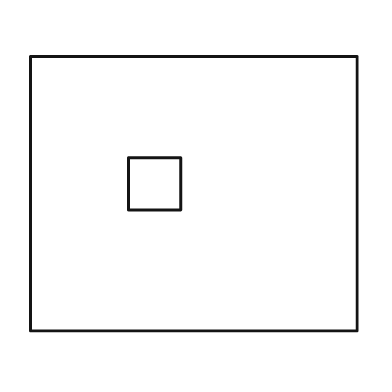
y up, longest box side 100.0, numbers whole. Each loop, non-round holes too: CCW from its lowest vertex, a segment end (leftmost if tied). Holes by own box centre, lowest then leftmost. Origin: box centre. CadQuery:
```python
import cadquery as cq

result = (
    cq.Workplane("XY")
    .moveTo(-50.0, -42.0)
    .lineTo(50.0, -42.0)
    .lineTo(50.0, 42.0)
    .lineTo(-50.0, 42.0)
    .close()
    .moveTo(-20.0, -5.0)
    .lineTo(-4.0, -5.0)
    .lineTo(-4.0, 11.0)
    .lineTo(-20.0, 11.0)
    .close()
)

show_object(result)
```